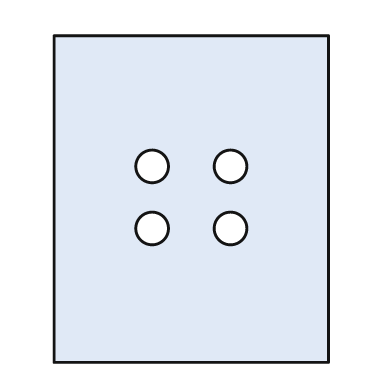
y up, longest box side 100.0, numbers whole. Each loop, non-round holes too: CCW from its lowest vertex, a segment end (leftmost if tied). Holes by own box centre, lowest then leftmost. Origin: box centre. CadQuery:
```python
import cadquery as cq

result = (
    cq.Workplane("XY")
    .moveTo(-42.0, -50.0)
    .lineTo(42.0, -50.0)
    .lineTo(42.0, 50.0)
    .lineTo(-42.0, 50.0)
    .close()
    .moveTo(-12.0, -9.0)
    .circle(5.0)
    .moveTo(12.0, -9.0)
    .circle(5.0)
    .moveTo(-12.0, 10.0)
    .circle(5.0)
    .moveTo(12.0, 10.0)
    .circle(5.0)
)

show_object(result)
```